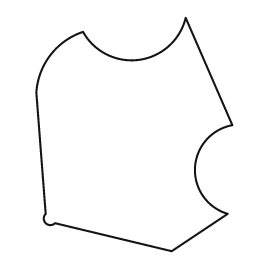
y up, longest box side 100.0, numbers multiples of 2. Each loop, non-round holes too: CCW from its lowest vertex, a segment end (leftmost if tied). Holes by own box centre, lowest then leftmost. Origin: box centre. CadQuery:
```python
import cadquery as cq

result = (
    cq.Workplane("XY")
    .moveTo(16.0, -50.0)
    .lineTo(40.0, -34.0)
    .threePointArc((26.0, -14.0), (42.0, 4.0))
    .lineTo(22.0, 50.0)
    .threePointArc((2.0, 32.0), (-22.0, 44.0))
    .threePointArc((-36.0, 34.0), (-42.0, 18.0))
    .lineTo(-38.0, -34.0)
    .threePointArc((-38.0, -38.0), (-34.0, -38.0))
    .close()
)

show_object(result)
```